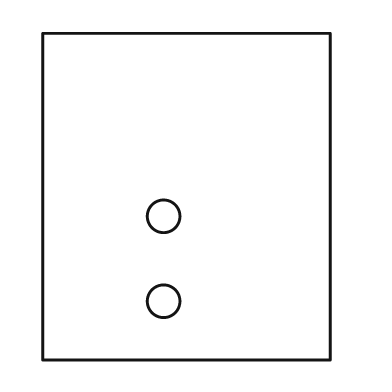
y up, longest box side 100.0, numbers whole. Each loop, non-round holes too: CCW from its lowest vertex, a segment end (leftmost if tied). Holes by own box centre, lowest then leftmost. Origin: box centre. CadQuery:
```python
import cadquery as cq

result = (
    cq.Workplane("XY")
    .moveTo(-44.0, -50.0)
    .lineTo(44.0, -50.0)
    .lineTo(44.0, 50.0)
    .lineTo(-44.0, 50.0)
    .close()
    .moveTo(-7.0, -32.0)
    .circle(5.0)
    .moveTo(-7.0, -6.0)
    .circle(5.0)
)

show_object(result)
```